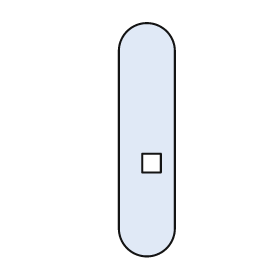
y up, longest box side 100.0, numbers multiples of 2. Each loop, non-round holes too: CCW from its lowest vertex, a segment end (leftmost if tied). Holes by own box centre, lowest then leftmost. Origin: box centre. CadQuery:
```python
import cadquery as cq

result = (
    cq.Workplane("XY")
    .moveTo(-12.0, -38.0)
    .threePointArc((0.0, -50.0), (12.0, -38.0))
    .lineTo(12.0, 38.0)
    .threePointArc((0.0, 50.0), (-12.0, 38.0))
    .close()
    .moveTo(-2.0, -14.0)
    .lineTo(6.0, -14.0)
    .lineTo(6.0, -6.0)
    .lineTo(-2.0, -6.0)
    .close()
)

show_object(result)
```